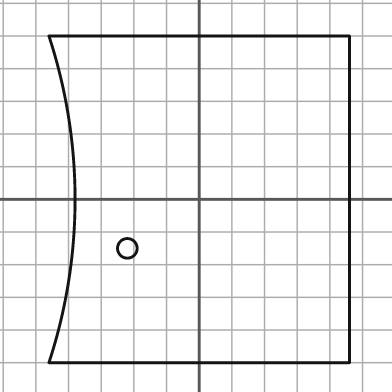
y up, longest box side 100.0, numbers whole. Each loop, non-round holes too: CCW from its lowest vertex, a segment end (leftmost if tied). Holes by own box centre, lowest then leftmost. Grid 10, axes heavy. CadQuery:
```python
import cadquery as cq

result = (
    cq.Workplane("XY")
    .moveTo(-46.0, -50.0)
    .lineTo(46.0, -50.0)
    .lineTo(46.0, 50.0)
    .lineTo(-46.0, 50.0)
    .threePointArc((-38.0, 0.0), (-46.0, -50.0))
    .close()
    .moveTo(-22.0, -15.0)
    .circle(3.0)
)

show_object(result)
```